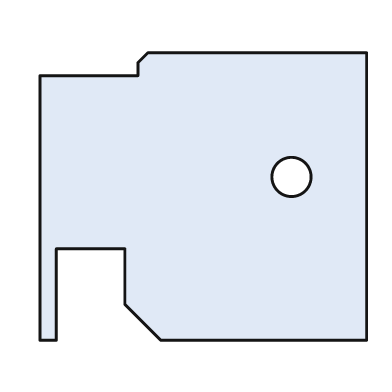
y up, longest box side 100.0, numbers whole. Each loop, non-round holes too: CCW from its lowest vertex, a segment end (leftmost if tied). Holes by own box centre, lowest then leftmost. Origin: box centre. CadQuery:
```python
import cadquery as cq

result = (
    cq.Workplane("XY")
    .moveTo(-50.0, -44.0)
    .lineTo(-45.0, -44.0)
    .lineTo(-45.0, -16.0)
    .lineTo(-24.0, -16.0)
    .lineTo(-24.0, -33.0)
    .lineTo(-13.0, -44.0)
    .lineTo(50.0, -44.0)
    .lineTo(50.0, 44.0)
    .lineTo(-17.0, 44.0)
    .lineTo(-20.0, 41.0)
    .lineTo(-20.0, 37.0)
    .lineTo(-50.0, 37.0)
    .close()
    .moveTo(27.0, 6.0)
    .circle(6.0)
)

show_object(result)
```